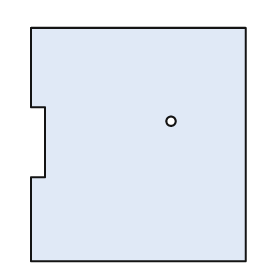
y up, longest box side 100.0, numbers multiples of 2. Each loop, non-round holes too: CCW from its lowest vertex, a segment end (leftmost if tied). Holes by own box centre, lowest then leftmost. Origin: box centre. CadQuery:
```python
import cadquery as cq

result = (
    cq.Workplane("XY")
    .moveTo(-46.0, -50.0)
    .lineTo(46.0, -50.0)
    .lineTo(46.0, 50.0)
    .lineTo(-46.0, 50.0)
    .lineTo(-46.0, 16.0)
    .lineTo(-40.0, 16.0)
    .lineTo(-40.0, -14.0)
    .lineTo(-46.0, -14.0)
    .close()
    .moveTo(14.0, 10.0)
    .circle(2.0)
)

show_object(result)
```